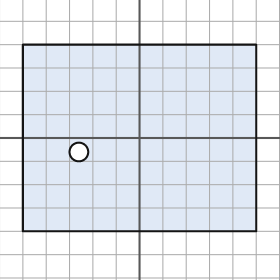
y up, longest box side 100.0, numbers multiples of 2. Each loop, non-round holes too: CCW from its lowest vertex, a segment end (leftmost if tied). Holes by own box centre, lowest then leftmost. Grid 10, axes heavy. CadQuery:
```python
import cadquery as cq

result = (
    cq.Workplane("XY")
    .moveTo(-50.0, -40.0)
    .lineTo(50.0, -40.0)
    .lineTo(50.0, 40.0)
    .lineTo(-50.0, 40.0)
    .close()
    .moveTo(-26.0, -6.0)
    .circle(4.0)
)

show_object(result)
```